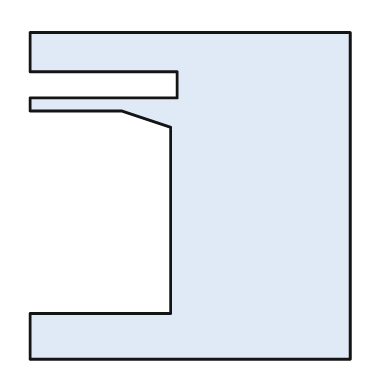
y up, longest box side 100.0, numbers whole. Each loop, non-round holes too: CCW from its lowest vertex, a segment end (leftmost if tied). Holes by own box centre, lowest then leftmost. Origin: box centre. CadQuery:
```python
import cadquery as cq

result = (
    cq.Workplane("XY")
    .moveTo(-49.0, -50.0)
    .lineTo(49.0, -50.0)
    .lineTo(49.0, 50.0)
    .lineTo(-49.0, 50.0)
    .lineTo(-49.0, 38.0)
    .lineTo(-4.0, 38.0)
    .lineTo(-4.0, 30.0)
    .lineTo(-49.0, 30.0)
    .lineTo(-49.0, 26.0)
    .lineTo(-21.0, 26.0)
    .lineTo(-6.0, 21.0)
    .lineTo(-6.0, -36.0)
    .lineTo(-49.0, -36.0)
    .close()
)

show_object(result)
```